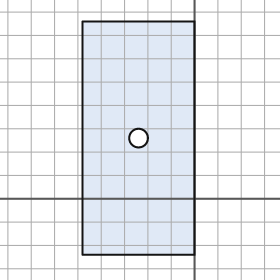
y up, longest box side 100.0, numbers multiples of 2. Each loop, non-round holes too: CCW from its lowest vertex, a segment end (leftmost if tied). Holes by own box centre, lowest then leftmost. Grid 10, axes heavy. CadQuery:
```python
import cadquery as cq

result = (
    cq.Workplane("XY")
    .moveTo(-48.0, -24.0)
    .lineTo(0.0, -24.0)
    .lineTo(0.0, 76.0)
    .lineTo(-48.0, 76.0)
    .close()
    .moveTo(-24.0, 26.0)
    .circle(4.0)
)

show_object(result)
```